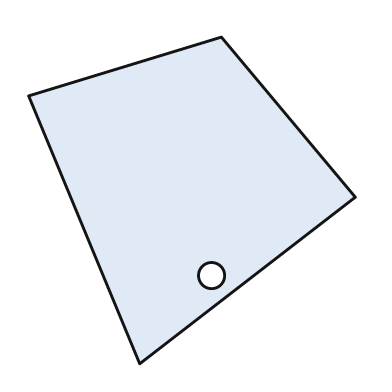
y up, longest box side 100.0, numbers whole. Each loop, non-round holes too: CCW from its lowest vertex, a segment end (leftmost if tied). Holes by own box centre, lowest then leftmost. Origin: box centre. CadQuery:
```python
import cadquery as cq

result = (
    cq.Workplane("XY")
    .moveTo(-16.0, -50.0)
    .lineTo(50.0, 1.0)
    .lineTo(9.0, 50.0)
    .lineTo(-50.0, 32.0)
    .close()
    .moveTo(6.0, -23.0)
    .circle(4.0)
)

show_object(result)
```